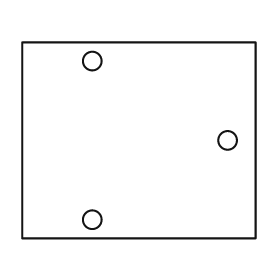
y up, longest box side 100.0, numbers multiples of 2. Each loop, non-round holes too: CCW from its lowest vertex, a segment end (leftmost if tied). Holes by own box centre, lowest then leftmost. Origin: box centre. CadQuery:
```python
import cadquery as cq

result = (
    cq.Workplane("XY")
    .moveTo(-50.0, -42.0)
    .lineTo(50.0, -42.0)
    .lineTo(50.0, 42.0)
    .lineTo(-50.0, 42.0)
    .close()
    .moveTo(-20.0, -34.0)
    .circle(4.0)
    .moveTo(38.0, 0.0)
    .circle(4.0)
    .moveTo(-20.0, 34.0)
    .circle(4.0)
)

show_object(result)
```